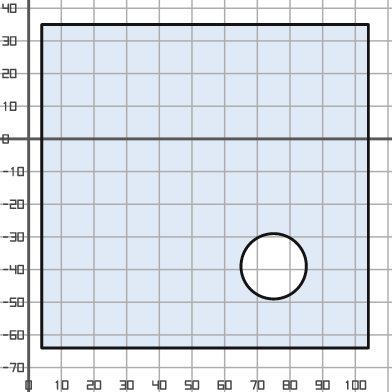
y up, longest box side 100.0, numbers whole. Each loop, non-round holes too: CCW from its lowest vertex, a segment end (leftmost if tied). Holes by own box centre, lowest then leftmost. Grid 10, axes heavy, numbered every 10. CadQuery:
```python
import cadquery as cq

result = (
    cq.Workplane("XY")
    .moveTo(4.0, -64.0)
    .lineTo(104.0, -64.0)
    .lineTo(104.0, 35.0)
    .lineTo(4.0, 35.0)
    .close()
    .moveTo(75.0, -39.0)
    .circle(10.0)
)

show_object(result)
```